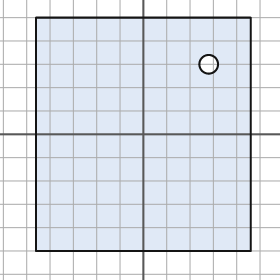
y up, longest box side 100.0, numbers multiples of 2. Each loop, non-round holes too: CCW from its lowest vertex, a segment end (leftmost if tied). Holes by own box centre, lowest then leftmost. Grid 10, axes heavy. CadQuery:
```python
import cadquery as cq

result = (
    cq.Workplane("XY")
    .moveTo(-46.0, -50.0)
    .lineTo(46.0, -50.0)
    .lineTo(46.0, 50.0)
    .lineTo(-46.0, 50.0)
    .close()
    .moveTo(28.0, 30.0)
    .circle(4.0)
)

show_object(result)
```